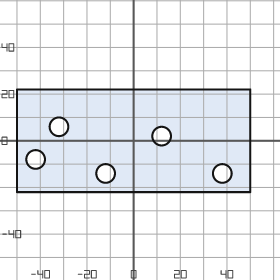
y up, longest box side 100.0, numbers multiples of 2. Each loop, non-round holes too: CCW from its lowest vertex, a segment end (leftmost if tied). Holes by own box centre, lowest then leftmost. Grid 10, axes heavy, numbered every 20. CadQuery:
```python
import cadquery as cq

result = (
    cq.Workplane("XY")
    .moveTo(-50.0, -22.0)
    .lineTo(50.0, -22.0)
    .lineTo(50.0, 22.0)
    .lineTo(-50.0, 22.0)
    .close()
    .moveTo(-12.0, -14.0)
    .circle(4.0)
    .moveTo(38.0, -14.0)
    .circle(4.0)
    .moveTo(-42.0, -8.0)
    .circle(4.0)
    .moveTo(12.0, 2.0)
    .circle(4.0)
    .moveTo(-32.0, 6.0)
    .circle(4.0)
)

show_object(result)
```